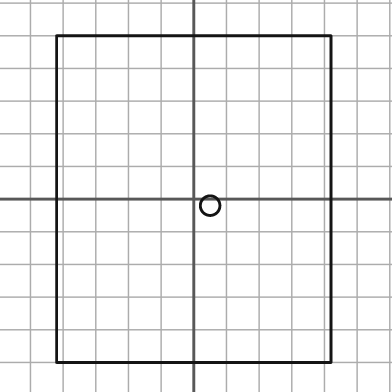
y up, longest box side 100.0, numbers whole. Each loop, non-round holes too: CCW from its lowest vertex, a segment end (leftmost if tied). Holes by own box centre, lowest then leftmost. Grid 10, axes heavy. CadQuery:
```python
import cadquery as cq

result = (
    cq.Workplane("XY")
    .moveTo(-42.0, -50.0)
    .lineTo(42.0, -50.0)
    .lineTo(42.0, 50.0)
    .lineTo(-42.0, 50.0)
    .close()
    .moveTo(5.0, -2.0)
    .circle(3.0)
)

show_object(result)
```